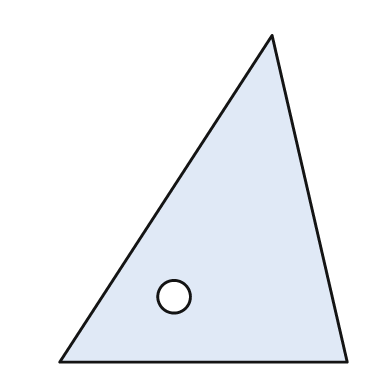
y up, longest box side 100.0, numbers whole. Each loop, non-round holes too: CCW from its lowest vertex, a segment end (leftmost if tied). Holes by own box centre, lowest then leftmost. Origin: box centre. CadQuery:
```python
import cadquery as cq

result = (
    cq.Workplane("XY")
    .moveTo(-44.0, -50.0)
    .lineTo(44.0, -50.0)
    .lineTo(21.0, 50.0)
    .close()
    .moveTo(-9.0, -30.0)
    .circle(5.0)
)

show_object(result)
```